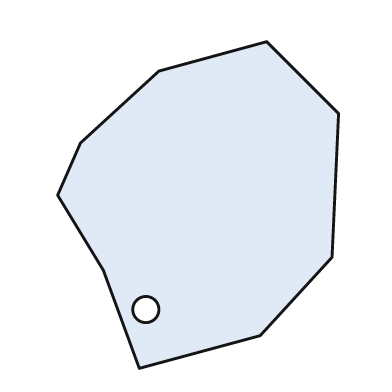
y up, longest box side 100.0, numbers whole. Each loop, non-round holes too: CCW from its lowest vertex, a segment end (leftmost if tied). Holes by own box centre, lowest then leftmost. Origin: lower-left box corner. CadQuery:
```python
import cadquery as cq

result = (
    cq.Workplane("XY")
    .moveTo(25.0, 0.0)
    .lineTo(62.0, 10.0)
    .lineTo(84.0, 34.0)
    .lineTo(86.0, 78.0)
    .lineTo(64.0, 100.0)
    .lineTo(31.0, 91.0)
    .lineTo(7.0, 69.0)
    .lineTo(0.0, 53.0)
    .lineTo(14.0, 30.0)
    .close()
    .moveTo(27.0, 18.0)
    .circle(4.0)
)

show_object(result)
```